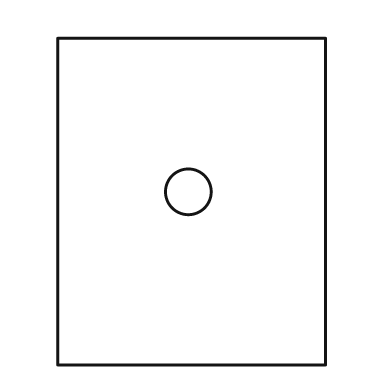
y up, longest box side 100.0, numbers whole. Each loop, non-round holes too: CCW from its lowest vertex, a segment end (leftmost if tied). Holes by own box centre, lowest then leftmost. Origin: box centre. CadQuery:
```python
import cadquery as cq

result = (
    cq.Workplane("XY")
    .moveTo(-41.0, -50.0)
    .lineTo(41.0, -50.0)
    .lineTo(41.0, 50.0)
    .lineTo(-41.0, 50.0)
    .close()
    .moveTo(-1.0, 3.0)
    .circle(7.0)
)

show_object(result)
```